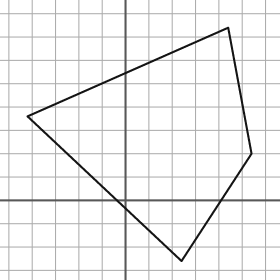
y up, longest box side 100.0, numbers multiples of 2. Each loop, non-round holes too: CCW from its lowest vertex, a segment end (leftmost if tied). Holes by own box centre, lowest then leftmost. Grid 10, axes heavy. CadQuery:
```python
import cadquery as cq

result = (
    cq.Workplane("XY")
    .moveTo(24.0, -26.0)
    .lineTo(54.0, 20.0)
    .lineTo(44.0, 74.0)
    .lineTo(-42.0, 36.0)
    .close()
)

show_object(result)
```